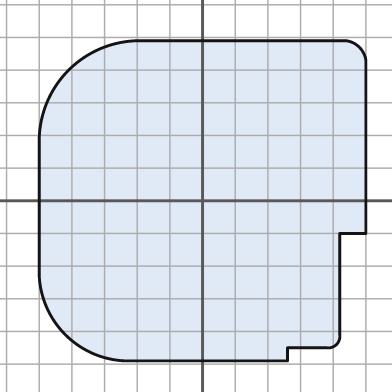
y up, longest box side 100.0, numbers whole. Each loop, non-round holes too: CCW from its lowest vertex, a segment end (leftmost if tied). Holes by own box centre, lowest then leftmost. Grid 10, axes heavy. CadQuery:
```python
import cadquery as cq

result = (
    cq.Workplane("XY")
    .moveTo(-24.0, -49.0)
    .lineTo(26.0, -49.0)
    .lineTo(26.0, -45.0)
    .lineTo(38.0, -45.0)
    .threePointArc((41.0, -44.0), (42.0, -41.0))
    .lineTo(42.0, -10.0)
    .lineTo(50.0, -10.0)
    .lineTo(50.0, 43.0)
    .threePointArc((48.0, 47.0), (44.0, 49.0))
    .lineTo(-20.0, 49.0)
    .threePointArc((-41.0, 40.0), (-50.0, 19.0))
    .lineTo(-50.0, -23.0)
    .threePointArc((-42.0, -41.0), (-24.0, -49.0))
    .close()
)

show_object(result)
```